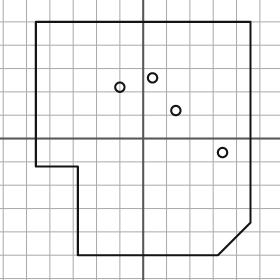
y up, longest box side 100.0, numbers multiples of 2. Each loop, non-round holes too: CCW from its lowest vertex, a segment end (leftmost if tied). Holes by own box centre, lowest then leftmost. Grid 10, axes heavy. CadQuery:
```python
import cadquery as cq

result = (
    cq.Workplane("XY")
    .moveTo(-28.0, -50.0)
    .lineTo(32.0, -50.0)
    .lineTo(46.0, -36.0)
    .lineTo(46.0, 50.0)
    .lineTo(-46.0, 50.0)
    .lineTo(-46.0, -12.0)
    .lineTo(-28.0, -12.0)
    .close()
    .moveTo(34.0, -6.0)
    .circle(2.0)
    .moveTo(14.0, 12.0)
    .circle(2.0)
    .moveTo(-10.0, 22.0)
    .circle(2.0)
    .moveTo(4.0, 26.0)
    .circle(2.0)
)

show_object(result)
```